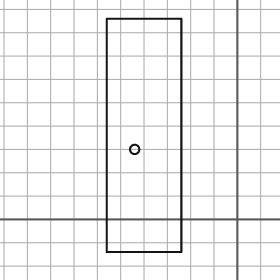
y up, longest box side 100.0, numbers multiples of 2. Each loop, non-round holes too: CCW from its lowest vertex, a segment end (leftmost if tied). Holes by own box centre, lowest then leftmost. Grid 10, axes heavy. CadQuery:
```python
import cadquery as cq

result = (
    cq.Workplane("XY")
    .moveTo(-56.0, -14.0)
    .lineTo(-24.0, -14.0)
    .lineTo(-24.0, 86.0)
    .lineTo(-56.0, 86.0)
    .close()
    .moveTo(-44.0, 30.0)
    .circle(2.0)
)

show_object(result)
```